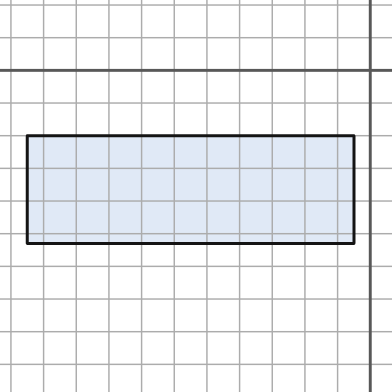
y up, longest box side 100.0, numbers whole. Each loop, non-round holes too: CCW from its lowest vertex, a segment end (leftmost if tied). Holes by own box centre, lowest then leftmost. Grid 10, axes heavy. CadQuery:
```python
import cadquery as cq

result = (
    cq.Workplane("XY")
    .moveTo(-105.0, -53.0)
    .lineTo(-5.0, -53.0)
    .lineTo(-5.0, -20.0)
    .lineTo(-105.0, -20.0)
    .close()
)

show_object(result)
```